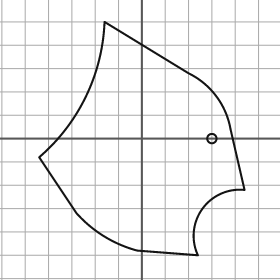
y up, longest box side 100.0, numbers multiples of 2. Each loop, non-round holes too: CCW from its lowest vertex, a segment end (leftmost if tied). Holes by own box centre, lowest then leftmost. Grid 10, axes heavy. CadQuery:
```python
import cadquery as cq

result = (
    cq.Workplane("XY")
    .moveTo(24.0, -50.0)
    .threePointArc((26.0, -30.0), (44.0, -22.0))
    .lineTo(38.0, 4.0)
    .threePointArc((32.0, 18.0), (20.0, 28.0))
    .lineTo(-16.0, 50.0)
    .threePointArc((-24.0, 18.0), (-44.0, -8.0))
    .lineTo(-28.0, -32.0)
    .threePointArc((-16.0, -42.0), (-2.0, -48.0))
    .close()
    .moveTo(30.0, 0.0)
    .circle(2.0)
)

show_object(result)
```